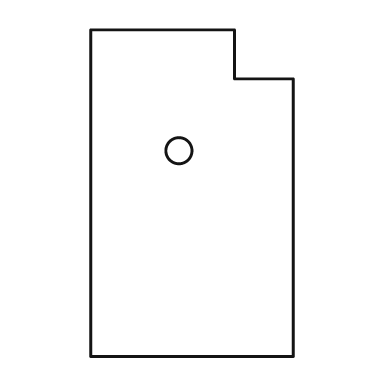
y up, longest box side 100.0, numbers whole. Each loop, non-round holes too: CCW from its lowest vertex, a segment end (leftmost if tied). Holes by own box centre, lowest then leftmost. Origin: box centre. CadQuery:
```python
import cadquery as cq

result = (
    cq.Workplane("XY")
    .moveTo(-31.0, -50.0)
    .lineTo(31.0, -50.0)
    .lineTo(31.0, 35.0)
    .lineTo(13.0, 35.0)
    .lineTo(13.0, 50.0)
    .lineTo(-31.0, 50.0)
    .close()
    .moveTo(-4.0, 13.0)
    .circle(4.0)
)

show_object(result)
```